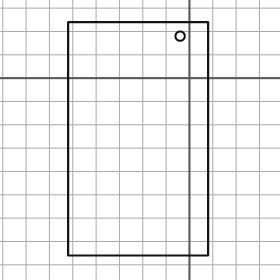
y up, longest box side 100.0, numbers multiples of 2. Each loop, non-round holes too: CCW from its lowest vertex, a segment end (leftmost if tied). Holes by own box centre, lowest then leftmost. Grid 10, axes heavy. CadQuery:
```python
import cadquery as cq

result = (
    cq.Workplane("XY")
    .moveTo(-52.0, -76.0)
    .lineTo(8.0, -76.0)
    .lineTo(8.0, 24.0)
    .lineTo(-52.0, 24.0)
    .close()
    .moveTo(-4.0, 18.0)
    .circle(2.0)
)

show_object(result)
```